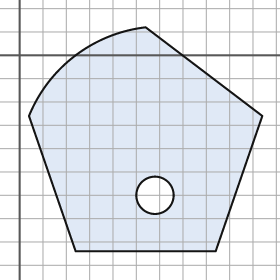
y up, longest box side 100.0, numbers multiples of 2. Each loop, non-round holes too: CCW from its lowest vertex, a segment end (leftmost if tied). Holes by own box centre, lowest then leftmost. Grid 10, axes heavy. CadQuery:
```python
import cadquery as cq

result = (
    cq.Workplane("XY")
    .moveTo(24.0, -84.0)
    .lineTo(84.0, -84.0)
    .lineTo(104.0, -26.0)
    .lineTo(54.0, 12.0)
    .threePointArc((24.0, 0.0), (4.0, -26.0))
    .close()
    .moveTo(58.0, -60.0)
    .circle(8.0)
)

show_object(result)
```